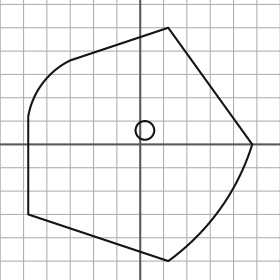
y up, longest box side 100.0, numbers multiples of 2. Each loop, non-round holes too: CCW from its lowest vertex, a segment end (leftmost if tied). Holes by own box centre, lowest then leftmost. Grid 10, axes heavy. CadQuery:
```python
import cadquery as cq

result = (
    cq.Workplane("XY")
    .moveTo(12.0, -50.0)
    .threePointArc((34.0, -28.0), (48.0, 0.0))
    .lineTo(12.0, 50.0)
    .lineTo(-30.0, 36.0)
    .threePointArc((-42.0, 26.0), (-48.0, 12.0))
    .lineTo(-48.0, -30.0)
    .close()
    .moveTo(2.0, 6.0)
    .circle(4.0)
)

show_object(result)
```